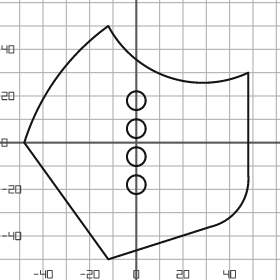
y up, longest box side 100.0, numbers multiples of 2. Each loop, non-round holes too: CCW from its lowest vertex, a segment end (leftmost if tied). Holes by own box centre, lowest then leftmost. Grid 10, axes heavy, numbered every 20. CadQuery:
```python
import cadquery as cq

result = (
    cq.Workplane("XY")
    .moveTo(-12.0, -50.0)
    .lineTo(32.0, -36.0)
    .threePointArc((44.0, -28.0), (48.0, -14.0))
    .lineTo(48.0, 30.0)
    .threePointArc((14.0, 28.0), (-12.0, 50.0))
    .threePointArc((-34.0, 28.0), (-48.0, 0.0))
    .close()
    .moveTo(0.0, -18.0)
    .circle(4.0)
    .moveTo(0.0, -6.0)
    .circle(4.0)
    .moveTo(0.0, 6.0)
    .circle(4.0)
    .moveTo(0.0, 18.0)
    .circle(4.0)
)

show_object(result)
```